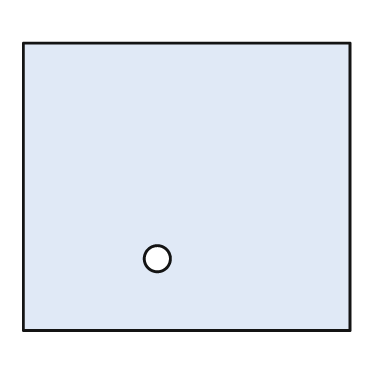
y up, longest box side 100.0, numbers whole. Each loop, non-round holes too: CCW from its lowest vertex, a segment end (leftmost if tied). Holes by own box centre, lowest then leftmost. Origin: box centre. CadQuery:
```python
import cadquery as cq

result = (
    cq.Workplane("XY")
    .moveTo(-50.0, -44.0)
    .lineTo(50.0, -44.0)
    .lineTo(50.0, 44.0)
    .lineTo(-50.0, 44.0)
    .close()
    .moveTo(-9.0, -22.0)
    .circle(4.0)
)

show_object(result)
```